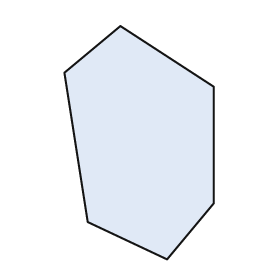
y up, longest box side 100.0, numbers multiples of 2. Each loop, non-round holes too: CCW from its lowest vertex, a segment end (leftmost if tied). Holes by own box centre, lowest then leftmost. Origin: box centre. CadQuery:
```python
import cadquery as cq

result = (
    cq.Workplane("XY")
    .moveTo(12.0, -50.0)
    .lineTo(32.0, -26.0)
    .lineTo(32.0, 24.0)
    .lineTo(-8.0, 50.0)
    .lineTo(-32.0, 30.0)
    .lineTo(-22.0, -34.0)
    .close()
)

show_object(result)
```